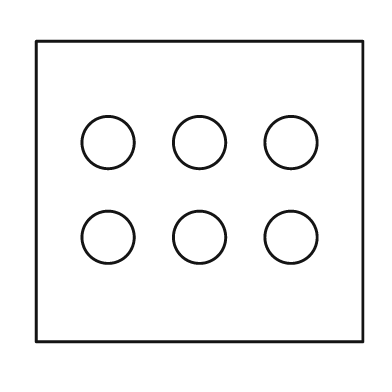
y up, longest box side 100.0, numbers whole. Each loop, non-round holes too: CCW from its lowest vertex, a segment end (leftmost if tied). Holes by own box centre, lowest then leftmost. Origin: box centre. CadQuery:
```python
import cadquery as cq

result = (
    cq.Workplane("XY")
    .moveTo(-50.0, -46.0)
    .lineTo(50.0, -46.0)
    .lineTo(50.0, 46.0)
    .lineTo(-50.0, 46.0)
    .close()
    .moveTo(-28.0, -14.0)
    .circle(8.0)
    .moveTo(0.0, -14.0)
    .circle(8.0)
    .moveTo(28.0, -14.0)
    .circle(8.0)
    .moveTo(-28.0, 15.0)
    .circle(8.0)
    .moveTo(0.0, 15.0)
    .circle(8.0)
    .moveTo(28.0, 15.0)
    .circle(8.0)
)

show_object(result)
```